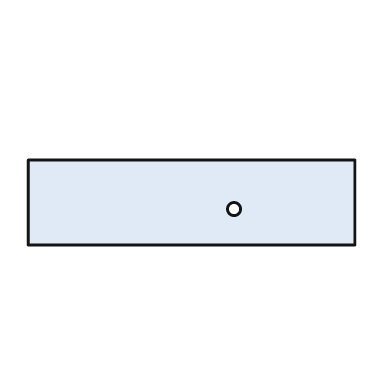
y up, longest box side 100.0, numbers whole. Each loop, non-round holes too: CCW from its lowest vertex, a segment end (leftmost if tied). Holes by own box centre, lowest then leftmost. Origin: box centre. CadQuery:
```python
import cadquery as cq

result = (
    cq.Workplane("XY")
    .moveTo(-50.0, -13.0)
    .lineTo(50.0, -13.0)
    .lineTo(50.0, 13.0)
    .lineTo(-50.0, 13.0)
    .close()
    .moveTo(13.0, -2.0)
    .circle(2.0)
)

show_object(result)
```